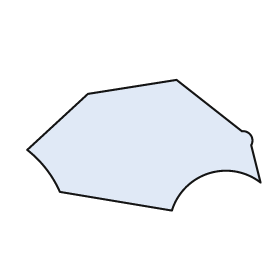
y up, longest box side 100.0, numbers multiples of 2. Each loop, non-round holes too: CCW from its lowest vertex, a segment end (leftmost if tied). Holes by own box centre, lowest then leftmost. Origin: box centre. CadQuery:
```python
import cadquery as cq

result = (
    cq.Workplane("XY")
    .moveTo(12.0, -28.0)
    .threePointArc((28.0, -12.0), (50.0, -16.0))
    .lineTo(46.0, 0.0)
    .threePointArc((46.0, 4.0), (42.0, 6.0))
    .lineTo(14.0, 28.0)
    .lineTo(-24.0, 22.0)
    .lineTo(-50.0, -2.0)
    .threePointArc((-42.0, -10.0), (-36.0, -20.0))
    .close()
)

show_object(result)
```